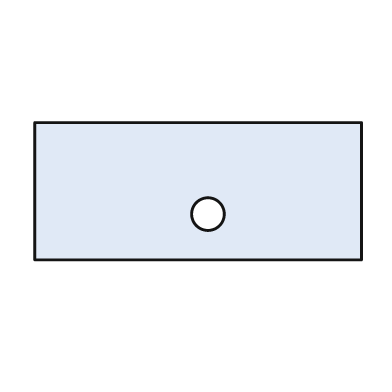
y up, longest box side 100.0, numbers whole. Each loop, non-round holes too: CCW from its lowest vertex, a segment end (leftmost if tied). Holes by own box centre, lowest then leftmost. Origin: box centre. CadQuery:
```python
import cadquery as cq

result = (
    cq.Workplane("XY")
    .moveTo(-50.0, -21.0)
    .lineTo(50.0, -21.0)
    .lineTo(50.0, 21.0)
    .lineTo(-50.0, 21.0)
    .close()
    .moveTo(3.0, -7.0)
    .circle(5.0)
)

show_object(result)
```